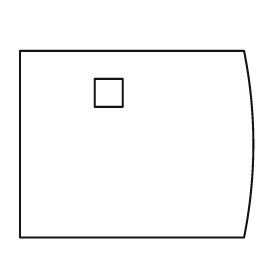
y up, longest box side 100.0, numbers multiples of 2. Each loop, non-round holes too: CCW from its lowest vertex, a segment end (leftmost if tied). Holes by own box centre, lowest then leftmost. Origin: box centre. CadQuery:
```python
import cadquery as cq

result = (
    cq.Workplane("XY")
    .moveTo(-50.0, -40.0)
    .lineTo(46.0, -40.0)
    .threePointArc((50.0, 0.0), (46.0, 40.0))
    .lineTo(-50.0, 40.0)
    .close()
    .moveTo(-18.0, 16.0)
    .lineTo(-6.0, 16.0)
    .lineTo(-6.0, 28.0)
    .lineTo(-18.0, 28.0)
    .close()
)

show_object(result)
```